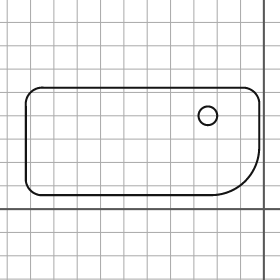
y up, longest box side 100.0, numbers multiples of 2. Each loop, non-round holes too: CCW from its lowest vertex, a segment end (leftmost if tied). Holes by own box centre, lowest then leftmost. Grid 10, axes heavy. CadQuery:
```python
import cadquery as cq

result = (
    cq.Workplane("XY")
    .moveTo(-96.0, 6.0)
    .lineTo(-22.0, 6.0)
    .threePointArc((-8.0, 12.0), (-2.0, 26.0))
    .lineTo(-2.0, 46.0)
    .threePointArc((-4.0, 50.0), (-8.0, 52.0))
    .lineTo(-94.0, 52.0)
    .threePointArc((-100.0, 50.0), (-102.0, 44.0))
    .lineTo(-102.0, 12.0)
    .threePointArc((-100.0, 8.0), (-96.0, 6.0))
    .close()
    .moveTo(-24.0, 40.0)
    .circle(4.0)
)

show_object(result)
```